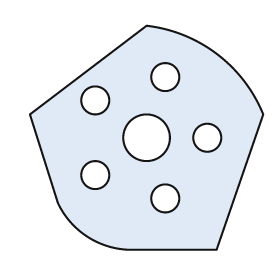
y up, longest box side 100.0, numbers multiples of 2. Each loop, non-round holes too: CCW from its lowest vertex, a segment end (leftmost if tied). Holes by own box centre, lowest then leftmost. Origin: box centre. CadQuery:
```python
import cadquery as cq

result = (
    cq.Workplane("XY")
    .moveTo(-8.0, -48.0)
    .lineTo(30.0, -48.0)
    .lineTo(50.0, 10.0)
    .threePointArc((30.0, 36.0), (0.0, 48.0))
    .lineTo(-50.0, 10.0)
    .lineTo(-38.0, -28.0)
    .threePointArc((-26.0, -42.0), (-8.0, -48.0))
    .close()
    .moveTo(8.0, -26.0)
    .circle(6.0)
    .moveTo(-22.0, -16.0)
    .circle(6.0)
    .moveTo(0.0, 0.0)
    .circle(10.0)
    .moveTo(26.0, 0.0)
    .circle(6.0)
    .moveTo(-22.0, 16.0)
    .circle(6.0)
    .moveTo(8.0, 26.0)
    .circle(6.0)
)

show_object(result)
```